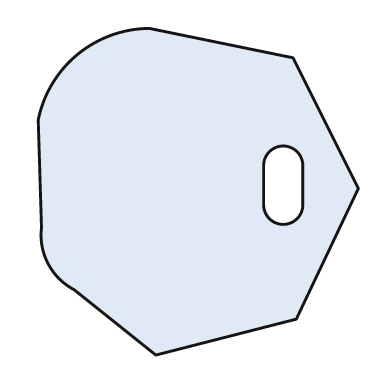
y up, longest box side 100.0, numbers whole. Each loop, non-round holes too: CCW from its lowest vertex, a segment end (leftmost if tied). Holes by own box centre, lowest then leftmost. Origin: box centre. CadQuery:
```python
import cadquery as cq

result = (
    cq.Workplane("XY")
    .moveTo(-13.0, -50.0)
    .lineTo(30.0, -39.0)
    .lineTo(49.0, 1.0)
    .lineTo(29.0, 41.0)
    .lineTo(-15.0, 50.0)
    .threePointArc((-37.0, 42.0), (-49.0, 22.0))
    .lineTo(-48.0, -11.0)
    .threePointArc((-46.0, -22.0), (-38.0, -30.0))
    .close()
    .moveTo(20.0, -4.0)
    .threePointArc((26.0, -10.0), (32.0, -4.0))
    .lineTo(32.0, 8.0)
    .threePointArc((26.0, 14.0), (20.0, 8.0))
    .close()
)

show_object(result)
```